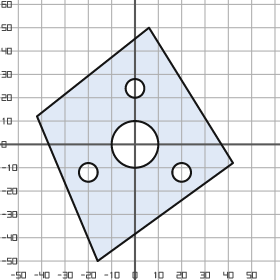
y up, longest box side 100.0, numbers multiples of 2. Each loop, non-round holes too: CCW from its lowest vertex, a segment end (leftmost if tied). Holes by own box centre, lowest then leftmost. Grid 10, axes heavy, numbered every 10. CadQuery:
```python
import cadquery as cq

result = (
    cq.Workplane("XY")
    .moveTo(-16.0, -50.0)
    .lineTo(42.0, -8.0)
    .lineTo(6.0, 50.0)
    .lineTo(-42.0, 12.0)
    .close()
    .moveTo(-20.0, -12.0)
    .circle(4.0)
    .moveTo(20.0, -12.0)
    .circle(4.0)
    .moveTo(0.0, 0.0)
    .circle(10.0)
    .moveTo(0.0, 24.0)
    .circle(4.0)
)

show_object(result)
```